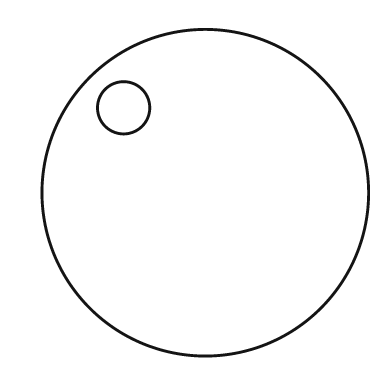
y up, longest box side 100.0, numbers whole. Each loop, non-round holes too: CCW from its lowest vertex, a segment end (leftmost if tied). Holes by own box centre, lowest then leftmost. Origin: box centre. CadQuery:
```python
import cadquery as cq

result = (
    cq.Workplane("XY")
    .moveTo(0.0, 0.0)
    .circle(50.0)
    .moveTo(-25.0, 26.0)
    .circle(8.0)
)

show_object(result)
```